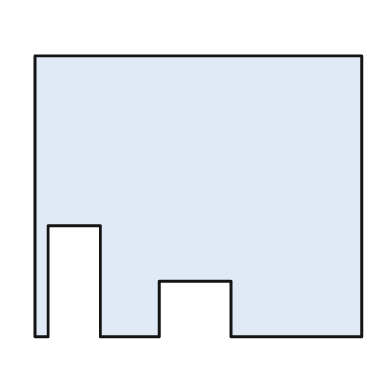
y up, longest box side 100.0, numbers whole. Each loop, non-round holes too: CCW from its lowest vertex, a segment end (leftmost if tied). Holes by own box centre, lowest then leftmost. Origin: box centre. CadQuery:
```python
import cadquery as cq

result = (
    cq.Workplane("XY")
    .moveTo(-50.0, -43.0)
    .lineTo(-46.0, -43.0)
    .lineTo(-46.0, -9.0)
    .lineTo(-30.0, -9.0)
    .lineTo(-30.0, -43.0)
    .lineTo(-12.0, -43.0)
    .lineTo(-12.0, -26.0)
    .lineTo(10.0, -26.0)
    .lineTo(10.0, -43.0)
    .lineTo(50.0, -43.0)
    .lineTo(50.0, 43.0)
    .lineTo(-50.0, 43.0)
    .close()
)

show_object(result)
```